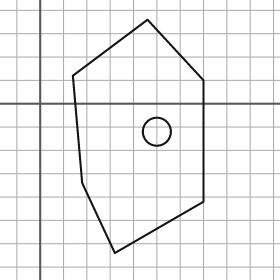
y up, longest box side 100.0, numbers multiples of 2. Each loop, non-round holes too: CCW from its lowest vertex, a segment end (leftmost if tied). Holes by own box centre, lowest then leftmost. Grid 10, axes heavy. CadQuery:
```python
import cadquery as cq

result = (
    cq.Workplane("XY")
    .moveTo(32.0, -64.0)
    .lineTo(70.0, -42.0)
    .lineTo(70.0, 10.0)
    .lineTo(46.0, 36.0)
    .lineTo(14.0, 12.0)
    .lineTo(18.0, -34.0)
    .close()
    .moveTo(50.0, -12.0)
    .circle(6.0)
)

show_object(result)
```